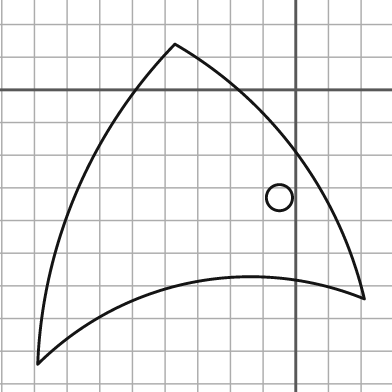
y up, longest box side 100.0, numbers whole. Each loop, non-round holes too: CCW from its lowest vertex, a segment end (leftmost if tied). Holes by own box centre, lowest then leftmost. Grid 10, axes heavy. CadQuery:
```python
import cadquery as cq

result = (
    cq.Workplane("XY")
    .moveTo(-79.0, -84.0)
    .threePointArc((-32.0, -59.0), (21.0, -64.0))
    .threePointArc((0.0, -19.0), (-37.0, 14.0))
    .threePointArc((-67.0, -31.0), (-79.0, -84.0))
    .close()
    .moveTo(-5.0, -33.0)
    .circle(4.0)
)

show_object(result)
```